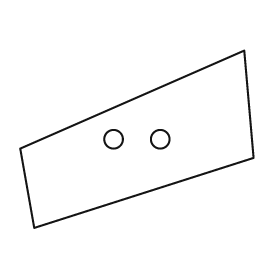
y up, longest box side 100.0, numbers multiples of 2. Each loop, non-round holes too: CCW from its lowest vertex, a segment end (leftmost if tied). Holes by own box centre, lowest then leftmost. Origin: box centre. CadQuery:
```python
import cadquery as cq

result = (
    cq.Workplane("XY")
    .moveTo(-44.0, -38.0)
    .lineTo(50.0, -8.0)
    .lineTo(46.0, 38.0)
    .lineTo(-50.0, -4.0)
    .close()
    .moveTo(-10.0, 0.0)
    .circle(4.0)
    .moveTo(10.0, 0.0)
    .circle(4.0)
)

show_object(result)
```